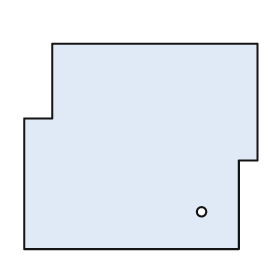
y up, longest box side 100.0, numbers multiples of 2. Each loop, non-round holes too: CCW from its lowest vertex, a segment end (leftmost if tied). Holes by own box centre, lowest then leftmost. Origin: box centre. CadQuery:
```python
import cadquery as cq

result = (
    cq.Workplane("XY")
    .moveTo(-50.0, -44.0)
    .lineTo(42.0, -44.0)
    .lineTo(42.0, -6.0)
    .lineTo(50.0, -6.0)
    .lineTo(50.0, 44.0)
    .lineTo(-38.0, 44.0)
    .lineTo(-38.0, 12.0)
    .lineTo(-50.0, 12.0)
    .close()
    .moveTo(26.0, -28.0)
    .circle(2.0)
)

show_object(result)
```